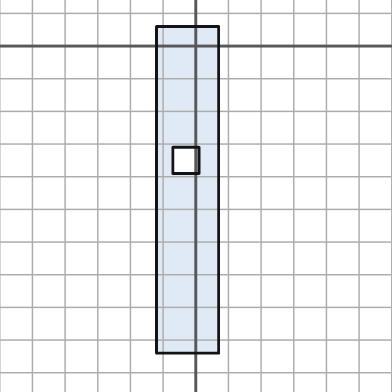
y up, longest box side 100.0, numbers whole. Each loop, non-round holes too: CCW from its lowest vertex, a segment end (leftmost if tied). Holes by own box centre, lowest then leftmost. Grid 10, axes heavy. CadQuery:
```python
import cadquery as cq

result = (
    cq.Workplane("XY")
    .moveTo(-12.0, -94.0)
    .lineTo(7.0, -94.0)
    .lineTo(7.0, 6.0)
    .lineTo(-12.0, 6.0)
    .close()
    .moveTo(-7.0, -39.0)
    .lineTo(1.0, -39.0)
    .lineTo(1.0, -31.0)
    .lineTo(-7.0, -31.0)
    .close()
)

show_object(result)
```